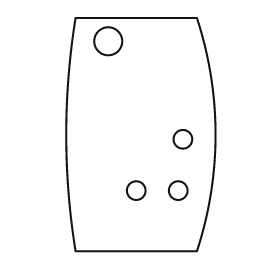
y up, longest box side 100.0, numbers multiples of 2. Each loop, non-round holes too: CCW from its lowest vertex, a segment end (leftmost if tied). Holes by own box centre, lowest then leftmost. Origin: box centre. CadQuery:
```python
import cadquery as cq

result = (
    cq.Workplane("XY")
    .moveTo(-28.0, -50.0)
    .lineTo(24.0, -50.0)
    .threePointArc((32.0, 0.0), (24.0, 50.0))
    .lineTo(-28.0, 50.0)
    .threePointArc((-32.0, 0.0), (-28.0, -50.0))
    .close()
    .moveTo(-2.0, -24.0)
    .circle(4.0)
    .moveTo(16.0, -24.0)
    .circle(4.0)
    .moveTo(18.0, -2.0)
    .circle(4.0)
    .moveTo(-14.0, 40.0)
    .circle(6.0)
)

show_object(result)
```